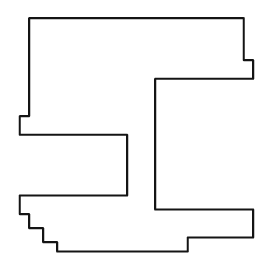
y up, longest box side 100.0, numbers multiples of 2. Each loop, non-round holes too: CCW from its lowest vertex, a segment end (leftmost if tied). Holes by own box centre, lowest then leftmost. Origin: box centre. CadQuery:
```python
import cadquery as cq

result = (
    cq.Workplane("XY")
    .moveTo(-34.0, -50.0)
    .lineTo(22.0, -50.0)
    .lineTo(22.0, -44.0)
    .lineTo(50.0, -44.0)
    .lineTo(50.0, -32.0)
    .lineTo(8.0, -32.0)
    .lineTo(8.0, 24.0)
    .lineTo(50.0, 24.0)
    .lineTo(50.0, 32.0)
    .lineTo(46.0, 32.0)
    .lineTo(46.0, 50.0)
    .lineTo(-46.0, 50.0)
    .lineTo(-46.0, 8.0)
    .lineTo(-50.0, 8.0)
    .lineTo(-50.0, 0.0)
    .lineTo(-4.0, 0.0)
    .lineTo(-4.0, -26.0)
    .lineTo(-50.0, -26.0)
    .lineTo(-50.0, -34.0)
    .lineTo(-46.0, -34.0)
    .lineTo(-46.0, -40.0)
    .lineTo(-40.0, -40.0)
    .lineTo(-40.0, -46.0)
    .lineTo(-34.0, -46.0)
    .close()
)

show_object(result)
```